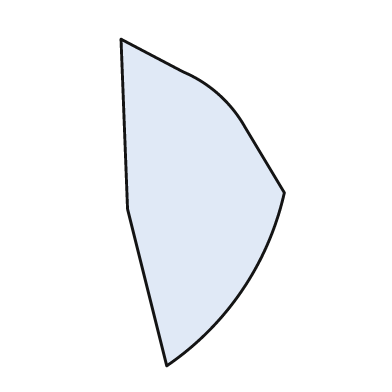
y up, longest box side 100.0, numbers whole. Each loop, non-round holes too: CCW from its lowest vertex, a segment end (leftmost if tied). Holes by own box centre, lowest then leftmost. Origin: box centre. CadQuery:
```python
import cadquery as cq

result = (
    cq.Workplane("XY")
    .moveTo(-11.0, -50.0)
    .threePointArc((12.0, -27.0), (25.0, 3.0))
    .lineTo(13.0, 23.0)
    .threePointArc((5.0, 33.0), (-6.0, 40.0))
    .lineTo(-25.0, 50.0)
    .lineTo(-23.0, -2.0)
    .close()
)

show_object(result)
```